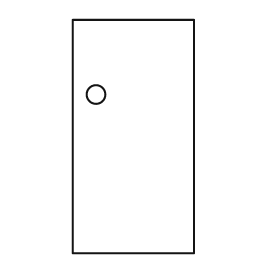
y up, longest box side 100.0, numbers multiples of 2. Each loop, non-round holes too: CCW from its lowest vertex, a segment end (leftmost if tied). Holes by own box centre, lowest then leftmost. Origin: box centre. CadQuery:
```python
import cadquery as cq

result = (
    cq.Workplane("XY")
    .moveTo(-26.0, -50.0)
    .lineTo(26.0, -50.0)
    .lineTo(26.0, 50.0)
    .lineTo(-26.0, 50.0)
    .close()
    .moveTo(-16.0, 18.0)
    .circle(4.0)
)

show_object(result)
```